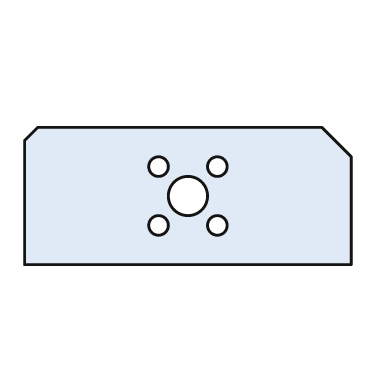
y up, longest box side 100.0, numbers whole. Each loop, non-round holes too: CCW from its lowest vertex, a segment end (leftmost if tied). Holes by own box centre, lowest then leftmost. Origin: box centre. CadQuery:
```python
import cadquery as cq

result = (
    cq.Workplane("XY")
    .moveTo(-50.0, -21.0)
    .lineTo(50.0, -21.0)
    .lineTo(50.0, 12.0)
    .lineTo(41.0, 21.0)
    .lineTo(-46.0, 21.0)
    .lineTo(-50.0, 17.0)
    .close()
    .moveTo(-9.0, -9.0)
    .circle(3.0)
    .moveTo(9.0, -9.0)
    .circle(3.0)
    .moveTo(0.0, 0.0)
    .circle(6.0)
    .moveTo(-9.0, 9.0)
    .circle(3.0)
    .moveTo(9.0, 9.0)
    .circle(3.0)
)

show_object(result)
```